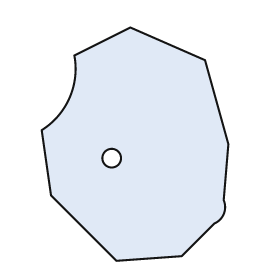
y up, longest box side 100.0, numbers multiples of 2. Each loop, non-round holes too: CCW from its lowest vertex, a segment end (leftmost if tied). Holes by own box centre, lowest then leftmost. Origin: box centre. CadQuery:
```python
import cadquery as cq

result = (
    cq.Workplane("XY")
    .moveTo(-8.0, -50.0)
    .lineTo(20.0, -48.0)
    .lineTo(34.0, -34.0)
    .threePointArc((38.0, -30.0), (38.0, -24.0))
    .lineTo(40.0, 0.0)
    .lineTo(30.0, 36.0)
    .lineTo(-2.0, 50.0)
    .lineTo(-26.0, 38.0)
    .threePointArc((-28.0, 20.0), (-40.0, 6.0))
    .lineTo(-36.0, -22.0)
    .close()
    .moveTo(-10.0, -6.0)
    .circle(4.0)
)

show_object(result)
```